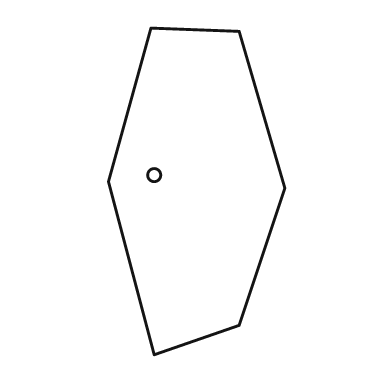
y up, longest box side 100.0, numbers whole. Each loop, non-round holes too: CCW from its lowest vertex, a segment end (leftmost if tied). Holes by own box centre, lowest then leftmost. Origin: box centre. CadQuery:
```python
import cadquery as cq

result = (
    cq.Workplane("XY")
    .moveTo(-13.0, -50.0)
    .lineTo(13.0, -41.0)
    .lineTo(27.0, 1.0)
    .lineTo(13.0, 49.0)
    .lineTo(-14.0, 50.0)
    .lineTo(-27.0, 3.0)
    .close()
    .moveTo(-13.0, 5.0)
    .circle(2.0)
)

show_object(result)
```